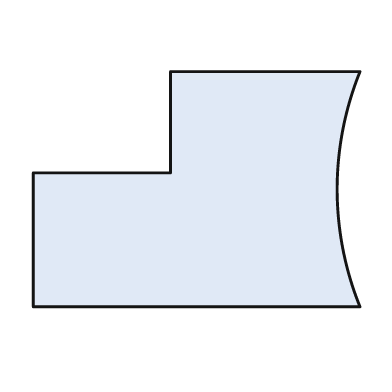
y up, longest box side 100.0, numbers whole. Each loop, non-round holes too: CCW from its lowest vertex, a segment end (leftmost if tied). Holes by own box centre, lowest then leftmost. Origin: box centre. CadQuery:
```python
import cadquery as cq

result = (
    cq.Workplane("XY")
    .moveTo(-50.0, -36.0)
    .lineTo(50.0, -36.0)
    .threePointArc((43.0, 0.0), (50.0, 36.0))
    .lineTo(-8.0, 36.0)
    .lineTo(-8.0, 5.0)
    .lineTo(-50.0, 5.0)
    .close()
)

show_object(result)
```